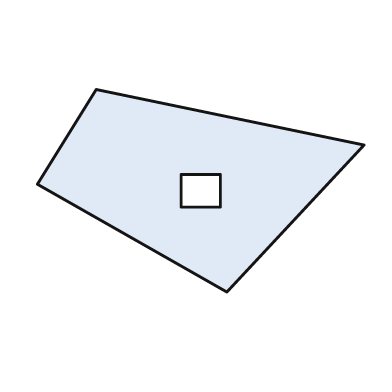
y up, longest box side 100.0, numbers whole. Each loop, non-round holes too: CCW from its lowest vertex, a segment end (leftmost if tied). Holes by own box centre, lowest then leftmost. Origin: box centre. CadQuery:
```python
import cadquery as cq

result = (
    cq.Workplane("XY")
    .moveTo(8.0, -31.0)
    .lineTo(50.0, 14.0)
    .lineTo(-32.0, 31.0)
    .lineTo(-50.0, 2.0)
    .close()
    .moveTo(-6.0, -5.0)
    .lineTo(6.0, -5.0)
    .lineTo(6.0, 5.0)
    .lineTo(-6.0, 5.0)
    .close()
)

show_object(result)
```